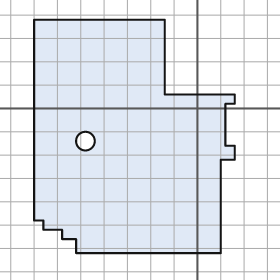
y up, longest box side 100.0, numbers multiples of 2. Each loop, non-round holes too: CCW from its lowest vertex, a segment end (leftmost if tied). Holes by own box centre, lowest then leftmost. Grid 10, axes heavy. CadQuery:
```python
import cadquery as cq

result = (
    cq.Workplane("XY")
    .moveTo(-52.0, -62.0)
    .lineTo(10.0, -62.0)
    .lineTo(10.0, -22.0)
    .lineTo(16.0, -22.0)
    .lineTo(16.0, -16.0)
    .lineTo(12.0, -16.0)
    .lineTo(12.0, 2.0)
    .lineTo(16.0, 2.0)
    .lineTo(16.0, 6.0)
    .lineTo(-14.0, 6.0)
    .lineTo(-14.0, 38.0)
    .lineTo(-70.0, 38.0)
    .lineTo(-70.0, -48.0)
    .lineTo(-66.0, -48.0)
    .lineTo(-66.0, -52.0)
    .lineTo(-58.0, -52.0)
    .lineTo(-58.0, -56.0)
    .lineTo(-52.0, -56.0)
    .close()
    .moveTo(-48.0, -14.0)
    .circle(4.0)
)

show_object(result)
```